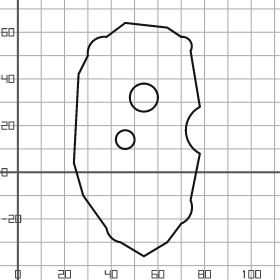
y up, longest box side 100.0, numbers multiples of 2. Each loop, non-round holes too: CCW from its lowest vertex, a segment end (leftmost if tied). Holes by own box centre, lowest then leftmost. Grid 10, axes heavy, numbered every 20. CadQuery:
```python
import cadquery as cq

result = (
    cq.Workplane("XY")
    .moveTo(54.0, -36.0)
    .lineTo(64.0, -30.0)
    .lineTo(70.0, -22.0)
    .threePointArc((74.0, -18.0), (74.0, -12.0))
    .lineTo(78.0, 8.0)
    .threePointArc((72.0, 18.0), (78.0, 28.0))
    .lineTo(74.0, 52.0)
    .threePointArc((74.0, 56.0), (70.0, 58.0))
    .lineTo(64.0, 62.0)
    .lineTo(46.0, 64.0)
    .lineTo(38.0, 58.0)
    .threePointArc((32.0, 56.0), (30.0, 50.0))
    .lineTo(26.0, 42.0)
    .lineTo(24.0, 4.0)
    .lineTo(28.0, -10.0)
    .lineTo(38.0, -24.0)
    .threePointArc((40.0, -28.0), (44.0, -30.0))
    .close()
    .moveTo(46.0, 14.0)
    .circle(4.0)
    .moveTo(54.0, 32.0)
    .circle(6.0)
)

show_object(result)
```